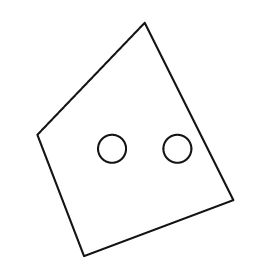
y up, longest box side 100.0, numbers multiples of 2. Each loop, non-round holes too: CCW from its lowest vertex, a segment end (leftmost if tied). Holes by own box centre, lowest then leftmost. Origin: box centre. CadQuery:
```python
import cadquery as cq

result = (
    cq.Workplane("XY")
    .moveTo(-22.0, -50.0)
    .lineTo(42.0, -26.0)
    .lineTo(4.0, 50.0)
    .lineTo(-42.0, 2.0)
    .close()
    .moveTo(-10.0, -4.0)
    .circle(6.0)
    .moveTo(18.0, -4.0)
    .circle(6.0)
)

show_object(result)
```